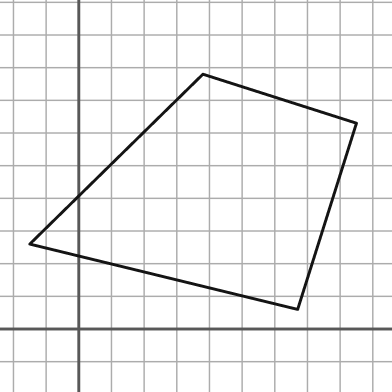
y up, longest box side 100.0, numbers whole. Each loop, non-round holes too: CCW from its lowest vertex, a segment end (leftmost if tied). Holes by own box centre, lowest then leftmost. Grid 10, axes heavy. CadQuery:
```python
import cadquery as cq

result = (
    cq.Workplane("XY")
    .moveTo(67.0, 6.0)
    .lineTo(85.0, 63.0)
    .lineTo(38.0, 78.0)
    .lineTo(-15.0, 26.0)
    .close()
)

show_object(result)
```